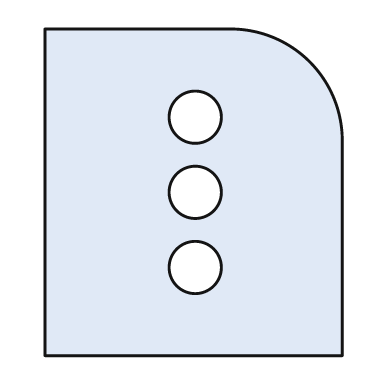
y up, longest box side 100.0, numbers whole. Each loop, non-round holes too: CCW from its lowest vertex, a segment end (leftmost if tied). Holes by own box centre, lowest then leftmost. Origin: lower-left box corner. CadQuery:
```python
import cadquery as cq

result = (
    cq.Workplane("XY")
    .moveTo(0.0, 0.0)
    .lineTo(91.0, 0.0)
    .lineTo(91.0, 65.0)
    .threePointArc((81.0, 90.0), (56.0, 100.0))
    .lineTo(0.0, 100.0)
    .close()
    .moveTo(46.0, 27.0)
    .circle(8.0)
    .moveTo(46.0, 50.0)
    .circle(8.0)
    .moveTo(46.0, 73.0)
    .circle(8.0)
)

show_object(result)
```